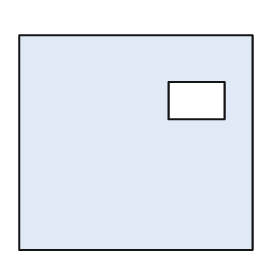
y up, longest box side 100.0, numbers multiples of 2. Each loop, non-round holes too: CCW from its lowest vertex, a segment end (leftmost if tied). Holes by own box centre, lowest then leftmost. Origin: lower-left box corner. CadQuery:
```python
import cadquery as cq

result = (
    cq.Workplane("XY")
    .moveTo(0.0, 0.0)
    .lineTo(100.0, 0.0)
    .lineTo(100.0, 92.0)
    .lineTo(0.0, 92.0)
    .close()
    .moveTo(64.0, 56.0)
    .lineTo(88.0, 56.0)
    .lineTo(88.0, 72.0)
    .lineTo(64.0, 72.0)
    .close()
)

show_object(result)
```